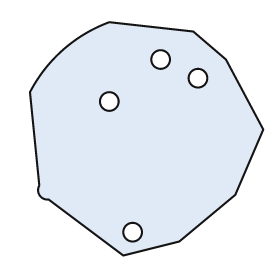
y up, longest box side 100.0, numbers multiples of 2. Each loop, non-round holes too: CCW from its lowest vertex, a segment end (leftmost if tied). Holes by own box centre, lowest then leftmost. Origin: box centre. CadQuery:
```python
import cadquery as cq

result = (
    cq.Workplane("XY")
    .moveTo(-10.0, -50.0)
    .lineTo(14.0, -44.0)
    .lineTo(38.0, -24.0)
    .lineTo(50.0, 4.0)
    .lineTo(34.0, 34.0)
    .lineTo(20.0, 46.0)
    .lineTo(-16.0, 50.0)
    .threePointArc((-36.0, 38.0), (-50.0, 20.0))
    .lineTo(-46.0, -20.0)
    .threePointArc((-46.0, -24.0), (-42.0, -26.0))
    .close()
    .moveTo(-6.0, -40.0)
    .circle(4.0)
    .moveTo(-16.0, 16.0)
    .circle(4.0)
    .moveTo(22.0, 26.0)
    .circle(4.0)
    .moveTo(6.0, 34.0)
    .circle(4.0)
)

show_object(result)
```